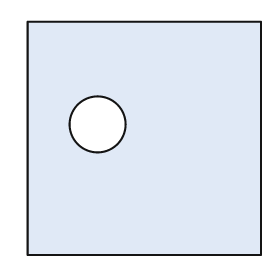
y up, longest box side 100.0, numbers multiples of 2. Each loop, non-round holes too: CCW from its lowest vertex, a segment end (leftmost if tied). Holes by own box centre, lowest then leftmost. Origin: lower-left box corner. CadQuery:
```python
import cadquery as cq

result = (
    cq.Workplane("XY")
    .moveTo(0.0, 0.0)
    .lineTo(100.0, 0.0)
    .lineTo(100.0, 100.0)
    .lineTo(0.0, 100.0)
    .close()
    .moveTo(30.0, 56.0)
    .circle(12.0)
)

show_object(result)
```